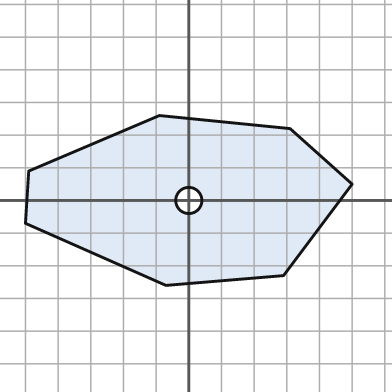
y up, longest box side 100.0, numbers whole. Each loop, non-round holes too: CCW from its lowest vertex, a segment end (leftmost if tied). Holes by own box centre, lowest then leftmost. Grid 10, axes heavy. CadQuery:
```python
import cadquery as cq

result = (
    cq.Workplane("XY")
    .moveTo(-7.0, -26.0)
    .lineTo(29.0, -23.0)
    .lineTo(50.0, 5.0)
    .lineTo(31.0, 22.0)
    .lineTo(-9.0, 26.0)
    .lineTo(-49.0, 9.0)
    .lineTo(-50.0, -7.0)
    .close()
    .moveTo(0.0, 0.0)
    .circle(4.0)
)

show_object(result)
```